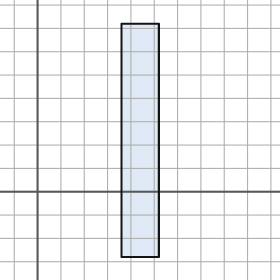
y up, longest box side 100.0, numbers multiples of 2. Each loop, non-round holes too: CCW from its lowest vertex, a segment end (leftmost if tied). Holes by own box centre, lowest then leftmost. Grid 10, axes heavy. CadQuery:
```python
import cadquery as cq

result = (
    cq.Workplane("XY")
    .moveTo(36.0, -28.0)
    .lineTo(52.0, -28.0)
    .lineTo(52.0, 72.0)
    .lineTo(36.0, 72.0)
    .close()
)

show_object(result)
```